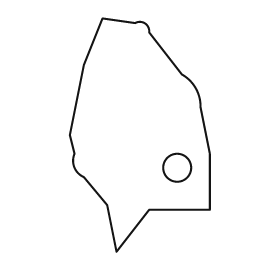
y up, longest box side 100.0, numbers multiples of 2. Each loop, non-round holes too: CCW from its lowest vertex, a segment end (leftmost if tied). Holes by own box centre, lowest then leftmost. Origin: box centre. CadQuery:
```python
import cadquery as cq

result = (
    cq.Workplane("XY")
    .moveTo(-10.0, -50.0)
    .lineTo(4.0, -32.0)
    .lineTo(30.0, -32.0)
    .lineTo(30.0, -8.0)
    .lineTo(26.0, 12.0)
    .threePointArc((24.0, 20.0), (18.0, 26.0))
    .lineTo(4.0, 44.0)
    .threePointArc((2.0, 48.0), (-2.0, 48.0))
    .lineTo(-16.0, 50.0)
    .lineTo(-24.0, 30.0)
    .lineTo(-30.0, 0.0)
    .lineTo(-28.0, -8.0)
    .threePointArc((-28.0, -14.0), (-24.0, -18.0))
    .lineTo(-14.0, -30.0)
    .close()
    .moveTo(16.0, -14.0)
    .circle(6.0)
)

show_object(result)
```